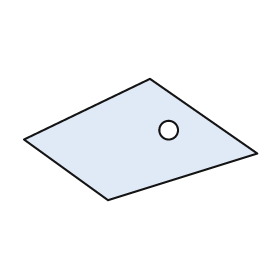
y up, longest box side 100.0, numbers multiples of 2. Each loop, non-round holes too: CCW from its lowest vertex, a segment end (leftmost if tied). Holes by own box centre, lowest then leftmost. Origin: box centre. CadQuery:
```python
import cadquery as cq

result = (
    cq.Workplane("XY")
    .moveTo(-14.0, -26.0)
    .lineTo(50.0, -6.0)
    .lineTo(4.0, 26.0)
    .lineTo(-50.0, 0.0)
    .close()
    .moveTo(12.0, 4.0)
    .circle(4.0)
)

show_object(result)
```